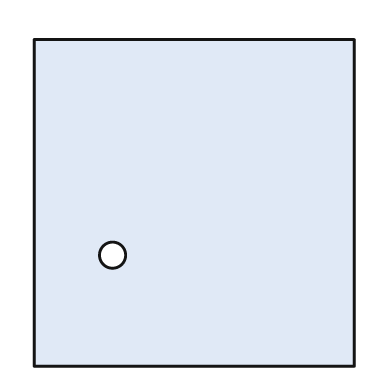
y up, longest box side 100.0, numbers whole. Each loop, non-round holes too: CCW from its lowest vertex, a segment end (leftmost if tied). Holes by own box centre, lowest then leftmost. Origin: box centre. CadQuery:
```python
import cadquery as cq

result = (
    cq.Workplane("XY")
    .moveTo(-49.0, -50.0)
    .lineTo(49.0, -50.0)
    .lineTo(49.0, 50.0)
    .lineTo(-49.0, 50.0)
    .close()
    .moveTo(-25.0, -16.0)
    .circle(4.0)
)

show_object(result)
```